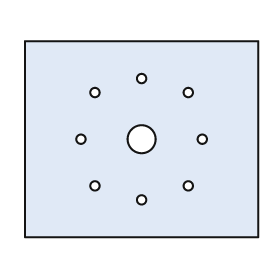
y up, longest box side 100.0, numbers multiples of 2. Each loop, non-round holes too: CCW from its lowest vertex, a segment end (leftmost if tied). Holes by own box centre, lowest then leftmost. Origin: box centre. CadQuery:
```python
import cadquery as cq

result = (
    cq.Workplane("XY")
    .moveTo(-50.0, -42.0)
    .lineTo(50.0, -42.0)
    .lineTo(50.0, 42.0)
    .lineTo(-50.0, 42.0)
    .close()
    .moveTo(0.0, -26.0)
    .circle(2.0)
    .moveTo(-20.0, -20.0)
    .circle(2.0)
    .moveTo(20.0, -20.0)
    .circle(2.0)
    .moveTo(-26.0, 0.0)
    .circle(2.0)
    .moveTo(0.0, 0.0)
    .circle(6.0)
    .moveTo(26.0, 0.0)
    .circle(2.0)
    .moveTo(-20.0, 20.0)
    .circle(2.0)
    .moveTo(20.0, 20.0)
    .circle(2.0)
    .moveTo(0.0, 26.0)
    .circle(2.0)
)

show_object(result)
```